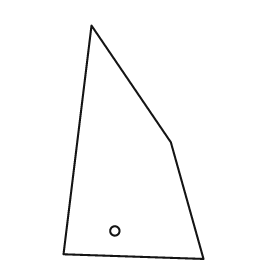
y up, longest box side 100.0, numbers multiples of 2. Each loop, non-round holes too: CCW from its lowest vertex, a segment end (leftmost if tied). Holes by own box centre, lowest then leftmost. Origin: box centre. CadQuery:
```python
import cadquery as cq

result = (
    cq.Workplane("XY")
    .moveTo(30.0, -50.0)
    .lineTo(16.0, 0.0)
    .lineTo(-18.0, 50.0)
    .lineTo(-30.0, -48.0)
    .close()
    .moveTo(-8.0, -38.0)
    .circle(2.0)
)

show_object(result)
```